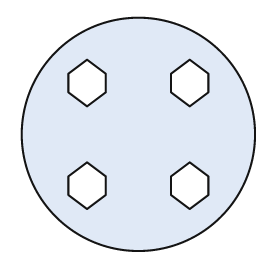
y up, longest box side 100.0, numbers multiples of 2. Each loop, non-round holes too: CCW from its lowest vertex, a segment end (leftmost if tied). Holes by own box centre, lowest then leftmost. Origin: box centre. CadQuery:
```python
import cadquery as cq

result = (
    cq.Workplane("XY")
    .moveTo(0.0, 0.0)
    .circle(50.0)
    .moveTo(-22.0, -32.0)
    .lineTo(-14.0, -26.0)
    .lineTo(-14.0, -18.0)
    .lineTo(-22.0, -12.0)
    .lineTo(-30.0, -18.0)
    .lineTo(-30.0, -26.0)
    .close()
    .moveTo(22.0, -32.0)
    .lineTo(30.0, -26.0)
    .lineTo(30.0, -18.0)
    .lineTo(22.0, -12.0)
    .lineTo(14.0, -18.0)
    .lineTo(14.0, -26.0)
    .close()
    .moveTo(-22.0, 12.0)
    .lineTo(-14.0, 18.0)
    .lineTo(-14.0, 26.0)
    .lineTo(-22.0, 32.0)
    .lineTo(-30.0, 26.0)
    .lineTo(-30.0, 18.0)
    .close()
    .moveTo(22.0, 12.0)
    .lineTo(30.0, 18.0)
    .lineTo(30.0, 26.0)
    .lineTo(22.0, 32.0)
    .lineTo(14.0, 26.0)
    .lineTo(14.0, 18.0)
    .close()
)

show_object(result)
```